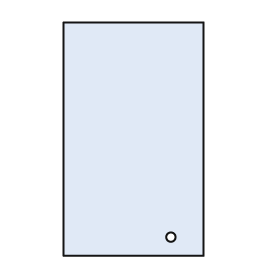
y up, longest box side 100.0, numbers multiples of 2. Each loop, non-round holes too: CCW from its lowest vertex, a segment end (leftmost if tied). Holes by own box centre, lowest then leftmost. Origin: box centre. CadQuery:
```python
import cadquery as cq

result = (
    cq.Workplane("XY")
    .moveTo(-30.0, -50.0)
    .lineTo(30.0, -50.0)
    .lineTo(30.0, 50.0)
    .lineTo(-30.0, 50.0)
    .close()
    .moveTo(16.0, -42.0)
    .circle(2.0)
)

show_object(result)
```